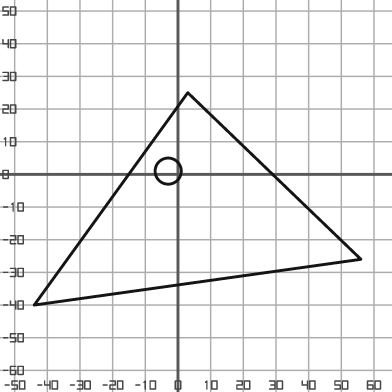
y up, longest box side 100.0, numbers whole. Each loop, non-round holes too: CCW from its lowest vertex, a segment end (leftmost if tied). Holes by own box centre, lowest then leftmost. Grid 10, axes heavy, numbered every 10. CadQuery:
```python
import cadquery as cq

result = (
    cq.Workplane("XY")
    .moveTo(-44.0, -40.0)
    .lineTo(56.0, -26.0)
    .lineTo(3.0, 25.0)
    .close()
    .moveTo(-3.0, 1.0)
    .circle(4.0)
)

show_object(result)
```